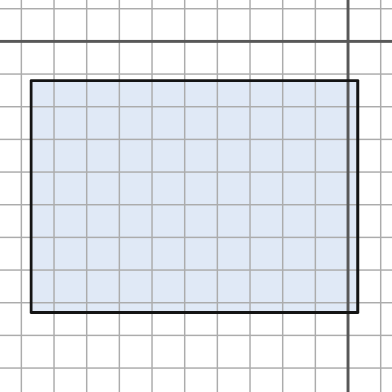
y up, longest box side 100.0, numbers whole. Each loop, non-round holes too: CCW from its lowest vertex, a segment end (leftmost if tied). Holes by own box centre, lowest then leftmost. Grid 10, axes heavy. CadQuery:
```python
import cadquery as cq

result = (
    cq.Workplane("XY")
    .moveTo(-97.0, -83.0)
    .lineTo(3.0, -83.0)
    .lineTo(3.0, -12.0)
    .lineTo(-97.0, -12.0)
    .close()
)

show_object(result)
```